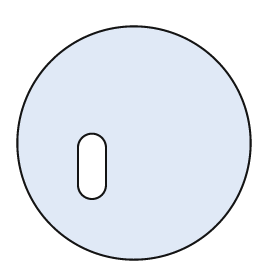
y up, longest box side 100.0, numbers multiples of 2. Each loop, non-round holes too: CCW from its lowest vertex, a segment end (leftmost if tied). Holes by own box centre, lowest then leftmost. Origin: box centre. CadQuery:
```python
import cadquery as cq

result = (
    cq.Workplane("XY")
    .moveTo(0.0, 0.0)
    .circle(50.0)
    .moveTo(-24.0, -18.0)
    .threePointArc((-18.0, -24.0), (-12.0, -18.0))
    .lineTo(-12.0, -2.0)
    .threePointArc((-18.0, 4.0), (-24.0, -2.0))
    .close()
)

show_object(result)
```